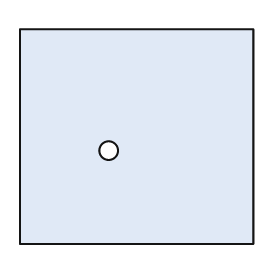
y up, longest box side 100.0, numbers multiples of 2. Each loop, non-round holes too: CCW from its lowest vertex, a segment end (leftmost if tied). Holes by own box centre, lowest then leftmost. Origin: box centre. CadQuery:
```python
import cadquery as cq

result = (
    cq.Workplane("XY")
    .moveTo(-50.0, -46.0)
    .lineTo(50.0, -46.0)
    .lineTo(50.0, 46.0)
    .lineTo(-50.0, 46.0)
    .close()
    .moveTo(-12.0, -6.0)
    .circle(4.0)
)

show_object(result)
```